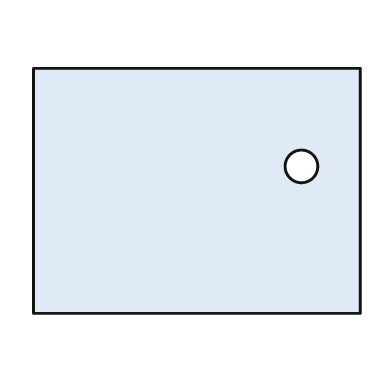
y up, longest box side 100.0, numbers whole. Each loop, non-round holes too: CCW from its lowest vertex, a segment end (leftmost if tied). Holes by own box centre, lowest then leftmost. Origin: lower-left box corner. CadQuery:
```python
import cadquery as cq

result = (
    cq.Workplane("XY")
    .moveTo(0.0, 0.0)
    .lineTo(100.0, 0.0)
    .lineTo(100.0, 75.0)
    .lineTo(0.0, 75.0)
    .close()
    .moveTo(82.0, 45.0)
    .circle(5.0)
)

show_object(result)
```